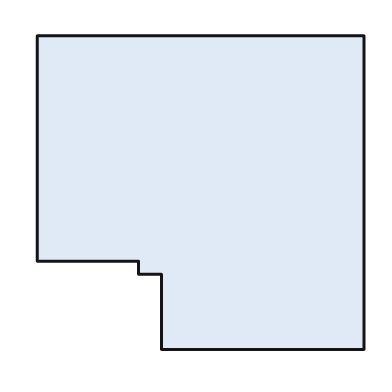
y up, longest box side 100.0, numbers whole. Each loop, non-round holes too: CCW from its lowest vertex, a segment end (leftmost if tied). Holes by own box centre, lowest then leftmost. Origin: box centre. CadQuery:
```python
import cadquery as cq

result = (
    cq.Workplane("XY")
    .moveTo(-12.0, -48.0)
    .lineTo(50.0, -48.0)
    .lineTo(50.0, 48.0)
    .lineTo(-50.0, 48.0)
    .lineTo(-50.0, -21.0)
    .lineTo(-19.0, -21.0)
    .lineTo(-19.0, -25.0)
    .lineTo(-12.0, -25.0)
    .close()
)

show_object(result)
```